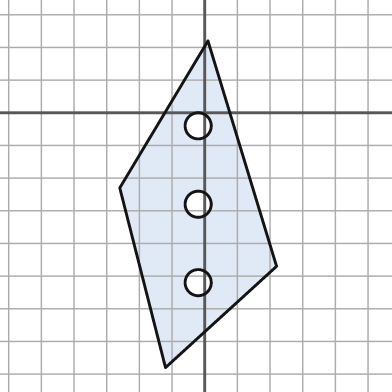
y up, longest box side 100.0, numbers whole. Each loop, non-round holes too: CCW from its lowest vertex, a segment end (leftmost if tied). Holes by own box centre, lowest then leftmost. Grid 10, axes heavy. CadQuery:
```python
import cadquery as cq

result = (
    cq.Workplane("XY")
    .moveTo(-12.0, -78.0)
    .lineTo(22.0, -47.0)
    .lineTo(1.0, 22.0)
    .lineTo(-26.0, -23.0)
    .close()
    .moveTo(-2.0, -52.0)
    .circle(4.0)
    .moveTo(-2.0, -28.0)
    .circle(4.0)
    .moveTo(-2.0, -4.0)
    .circle(4.0)
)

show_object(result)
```